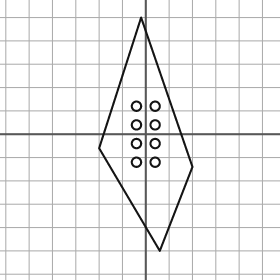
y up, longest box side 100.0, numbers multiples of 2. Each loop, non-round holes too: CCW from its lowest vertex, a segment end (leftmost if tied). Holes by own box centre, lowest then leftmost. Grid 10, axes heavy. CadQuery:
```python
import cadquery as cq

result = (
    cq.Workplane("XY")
    .moveTo(6.0, -50.0)
    .lineTo(20.0, -14.0)
    .lineTo(-2.0, 50.0)
    .lineTo(-20.0, -6.0)
    .close()
    .moveTo(-4.0, -12.0)
    .circle(2.0)
    .moveTo(4.0, -12.0)
    .circle(2.0)
    .moveTo(-4.0, -4.0)
    .circle(2.0)
    .moveTo(4.0, -4.0)
    .circle(2.0)
    .moveTo(-4.0, 4.0)
    .circle(2.0)
    .moveTo(4.0, 4.0)
    .circle(2.0)
    .moveTo(-4.0, 12.0)
    .circle(2.0)
    .moveTo(4.0, 12.0)
    .circle(2.0)
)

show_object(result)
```